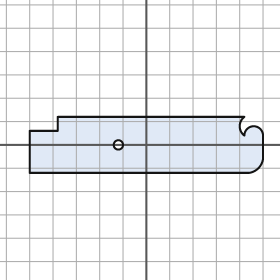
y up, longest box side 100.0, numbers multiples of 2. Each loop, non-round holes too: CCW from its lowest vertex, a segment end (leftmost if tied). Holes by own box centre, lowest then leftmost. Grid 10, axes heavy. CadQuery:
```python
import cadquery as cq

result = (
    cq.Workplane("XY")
    .moveTo(-50.0, -12.0)
    .lineTo(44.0, -12.0)
    .threePointArc((48.0, -10.0), (50.0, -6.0))
    .lineTo(50.0, 4.0)
    .threePointArc((46.0, 8.0), (42.0, 4.0))
    .threePointArc((40.0, 8.0), (42.0, 12.0))
    .lineTo(-38.0, 12.0)
    .lineTo(-38.0, 6.0)
    .lineTo(-50.0, 6.0)
    .close()
    .moveTo(-12.0, 0.0)
    .circle(2.0)
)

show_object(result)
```